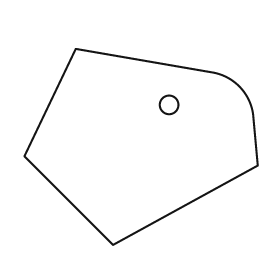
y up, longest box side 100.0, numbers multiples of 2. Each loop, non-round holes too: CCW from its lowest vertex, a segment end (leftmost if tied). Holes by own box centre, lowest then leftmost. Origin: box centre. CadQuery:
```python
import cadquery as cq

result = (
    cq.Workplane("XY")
    .moveTo(-12.0, -42.0)
    .lineTo(50.0, -8.0)
    .lineTo(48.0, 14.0)
    .threePointArc((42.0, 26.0), (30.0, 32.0))
    .lineTo(-28.0, 42.0)
    .lineTo(-50.0, -4.0)
    .close()
    .moveTo(12.0, 18.0)
    .circle(4.0)
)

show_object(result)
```